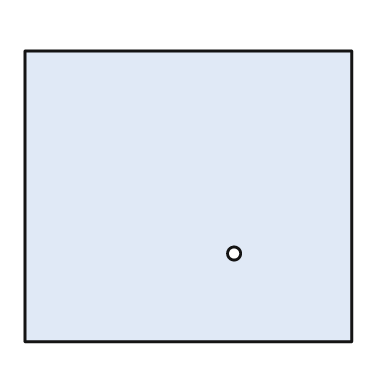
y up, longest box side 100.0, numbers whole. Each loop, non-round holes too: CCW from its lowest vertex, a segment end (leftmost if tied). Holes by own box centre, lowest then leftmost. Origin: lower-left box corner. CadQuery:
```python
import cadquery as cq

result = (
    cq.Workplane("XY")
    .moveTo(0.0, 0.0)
    .lineTo(100.0, 0.0)
    .lineTo(100.0, 89.0)
    .lineTo(0.0, 89.0)
    .close()
    .moveTo(64.0, 27.0)
    .circle(2.0)
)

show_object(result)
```